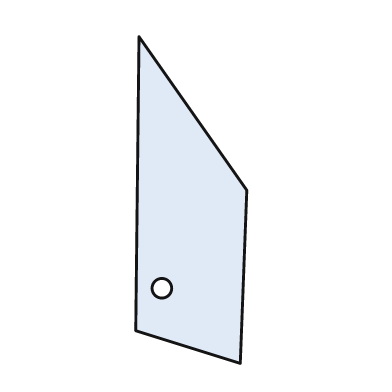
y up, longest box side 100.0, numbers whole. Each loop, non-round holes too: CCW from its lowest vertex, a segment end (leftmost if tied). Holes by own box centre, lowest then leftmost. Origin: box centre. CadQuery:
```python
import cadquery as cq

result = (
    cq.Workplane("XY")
    .moveTo(15.0, -50.0)
    .lineTo(17.0, 3.0)
    .lineTo(-16.0, 50.0)
    .lineTo(-17.0, -40.0)
    .close()
    .moveTo(-9.0, -27.0)
    .circle(3.0)
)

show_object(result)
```